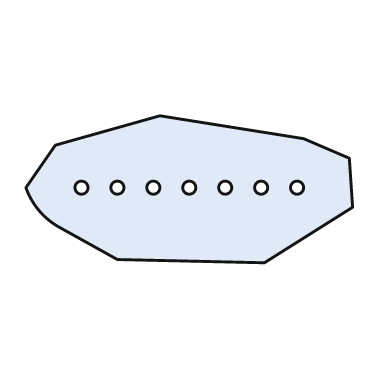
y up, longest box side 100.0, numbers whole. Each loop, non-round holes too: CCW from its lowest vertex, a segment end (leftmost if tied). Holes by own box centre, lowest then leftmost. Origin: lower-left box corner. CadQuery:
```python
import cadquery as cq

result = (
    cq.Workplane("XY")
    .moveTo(73.0, 0.0)
    .lineTo(100.0, 17.0)
    .lineTo(99.0, 32.0)
    .lineTo(85.0, 38.0)
    .lineTo(41.0, 45.0)
    .lineTo(9.0, 36.0)
    .lineTo(0.0, 23.0)
    .threePointArc((4.0, 16.0), (10.0, 11.0))
    .lineTo(28.0, 1.0)
    .close()
    .moveTo(17.0, 23.0)
    .circle(2.0)
    .moveTo(28.0, 23.0)
    .circle(2.0)
    .moveTo(39.0, 23.0)
    .circle(2.0)
    .moveTo(50.0, 23.0)
    .circle(2.0)
    .moveTo(61.0, 23.0)
    .circle(2.0)
    .moveTo(72.0, 23.0)
    .circle(2.0)
    .moveTo(83.0, 23.0)
    .circle(2.0)
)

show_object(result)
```